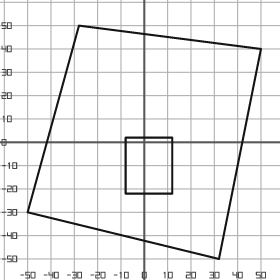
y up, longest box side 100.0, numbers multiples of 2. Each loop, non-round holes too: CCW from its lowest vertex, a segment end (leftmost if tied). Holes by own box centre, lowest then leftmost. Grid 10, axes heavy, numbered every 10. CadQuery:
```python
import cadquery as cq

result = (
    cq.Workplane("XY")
    .moveTo(32.0, -50.0)
    .lineTo(50.0, 40.0)
    .lineTo(-28.0, 50.0)
    .lineTo(-50.0, -30.0)
    .close()
    .moveTo(-8.0, -22.0)
    .lineTo(12.0, -22.0)
    .lineTo(12.0, 2.0)
    .lineTo(-8.0, 2.0)
    .close()
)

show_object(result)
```